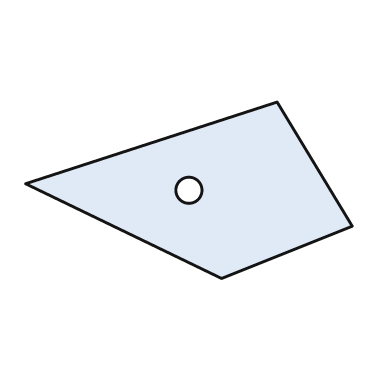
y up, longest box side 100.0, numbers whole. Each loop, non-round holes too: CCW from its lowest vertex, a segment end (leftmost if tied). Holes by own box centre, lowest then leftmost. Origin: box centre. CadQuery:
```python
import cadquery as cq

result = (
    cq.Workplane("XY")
    .moveTo(10.0, -27.0)
    .lineTo(50.0, -11.0)
    .lineTo(27.0, 27.0)
    .lineTo(-50.0, 2.0)
    .close()
    .moveTo(0.0, 0.0)
    .circle(4.0)
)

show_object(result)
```